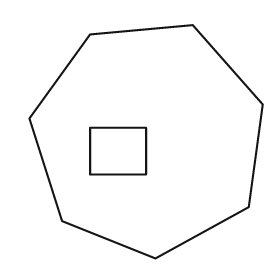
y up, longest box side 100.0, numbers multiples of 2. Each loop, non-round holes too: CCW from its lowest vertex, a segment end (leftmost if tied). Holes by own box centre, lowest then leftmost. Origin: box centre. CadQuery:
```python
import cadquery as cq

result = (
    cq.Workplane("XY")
    .moveTo(4.0, -50.0)
    .lineTo(44.0, -28.0)
    .lineTo(50.0, 16.0)
    .lineTo(20.0, 50.0)
    .lineTo(-24.0, 46.0)
    .lineTo(-50.0, 10.0)
    .lineTo(-36.0, -34.0)
    .close()
    .moveTo(-24.0, -14.0)
    .lineTo(0.0, -14.0)
    .lineTo(0.0, 6.0)
    .lineTo(-24.0, 6.0)
    .close()
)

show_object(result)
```